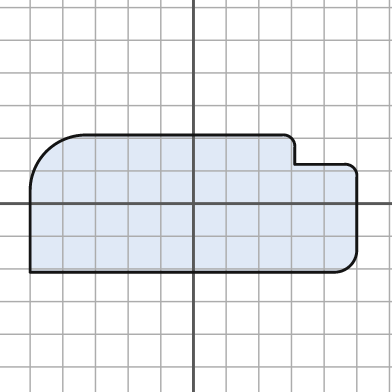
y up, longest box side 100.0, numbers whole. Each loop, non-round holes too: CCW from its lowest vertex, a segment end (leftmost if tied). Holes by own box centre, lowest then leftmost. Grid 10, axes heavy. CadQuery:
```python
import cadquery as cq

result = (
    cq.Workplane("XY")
    .moveTo(-50.0, -21.0)
    .lineTo(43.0, -21.0)
    .threePointArc((48.0, -19.0), (50.0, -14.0))
    .lineTo(50.0, 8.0)
    .threePointArc((49.0, 11.0), (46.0, 12.0))
    .lineTo(31.0, 12.0)
    .lineTo(31.0, 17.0)
    .threePointArc((30.0, 20.0), (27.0, 21.0))
    .lineTo(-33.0, 21.0)
    .threePointArc((-45.0, 16.0), (-50.0, 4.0))
    .close()
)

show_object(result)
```